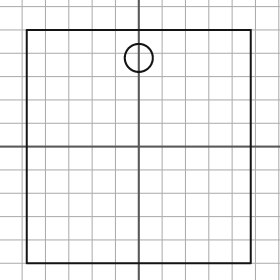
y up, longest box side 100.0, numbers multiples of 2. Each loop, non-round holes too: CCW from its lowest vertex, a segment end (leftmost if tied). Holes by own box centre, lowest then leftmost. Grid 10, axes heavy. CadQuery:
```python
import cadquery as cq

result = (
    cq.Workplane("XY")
    .moveTo(-48.0, -50.0)
    .lineTo(48.0, -50.0)
    .lineTo(48.0, 50.0)
    .lineTo(-48.0, 50.0)
    .close()
    .moveTo(0.0, 38.0)
    .circle(6.0)
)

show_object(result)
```